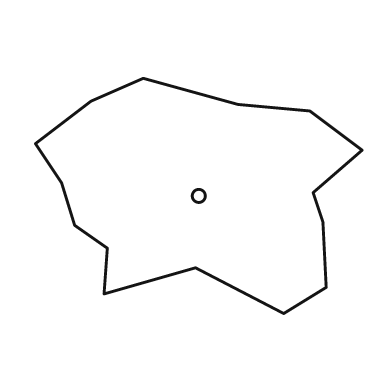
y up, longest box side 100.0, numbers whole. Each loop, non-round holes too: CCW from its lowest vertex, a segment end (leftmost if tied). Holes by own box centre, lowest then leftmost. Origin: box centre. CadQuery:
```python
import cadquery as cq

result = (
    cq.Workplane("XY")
    .moveTo(26.0, -36.0)
    .lineTo(39.0, -28.0)
    .lineTo(38.0, -8.0)
    .lineTo(35.0, 1.0)
    .lineTo(50.0, 14.0)
    .lineTo(34.0, 26.0)
    .lineTo(12.0, 28.0)
    .lineTo(-17.0, 36.0)
    .lineTo(-33.0, 29.0)
    .lineTo(-50.0, 16.0)
    .lineTo(-42.0, 4.0)
    .lineTo(-38.0, -9.0)
    .lineTo(-28.0, -16.0)
    .lineTo(-29.0, -30.0)
    .lineTo(-1.0, -22.0)
    .close()
    .moveTo(0.0, 0.0)
    .circle(2.0)
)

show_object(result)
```